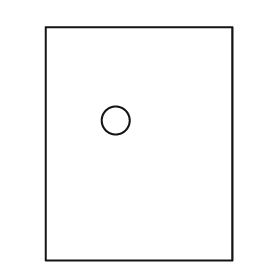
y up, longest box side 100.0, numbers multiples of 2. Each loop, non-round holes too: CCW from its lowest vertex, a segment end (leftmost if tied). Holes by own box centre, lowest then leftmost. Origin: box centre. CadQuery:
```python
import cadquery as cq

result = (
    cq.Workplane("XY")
    .moveTo(-40.0, -50.0)
    .lineTo(40.0, -50.0)
    .lineTo(40.0, 50.0)
    .lineTo(-40.0, 50.0)
    .close()
    .moveTo(-10.0, 10.0)
    .circle(6.0)
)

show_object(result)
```